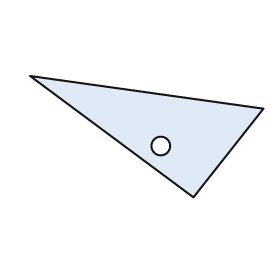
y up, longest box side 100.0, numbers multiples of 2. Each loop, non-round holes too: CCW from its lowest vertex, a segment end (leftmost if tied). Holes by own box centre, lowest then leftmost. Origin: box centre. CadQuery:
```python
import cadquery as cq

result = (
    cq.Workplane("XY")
    .moveTo(20.0, -26.0)
    .lineTo(50.0, 12.0)
    .lineTo(-50.0, 26.0)
    .close()
    .moveTo(6.0, -4.0)
    .circle(4.0)
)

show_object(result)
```